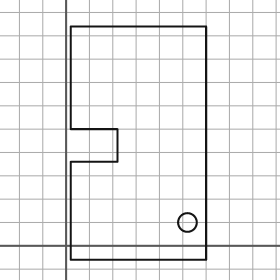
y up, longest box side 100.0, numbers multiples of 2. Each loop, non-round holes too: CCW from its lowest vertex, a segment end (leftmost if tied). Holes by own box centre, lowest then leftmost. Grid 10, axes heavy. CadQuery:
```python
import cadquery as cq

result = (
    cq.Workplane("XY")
    .moveTo(2.0, -6.0)
    .lineTo(60.0, -6.0)
    .lineTo(60.0, 94.0)
    .lineTo(2.0, 94.0)
    .lineTo(2.0, 50.0)
    .lineTo(22.0, 50.0)
    .lineTo(22.0, 36.0)
    .lineTo(2.0, 36.0)
    .close()
    .moveTo(52.0, 10.0)
    .circle(4.0)
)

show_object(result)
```